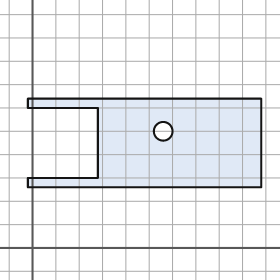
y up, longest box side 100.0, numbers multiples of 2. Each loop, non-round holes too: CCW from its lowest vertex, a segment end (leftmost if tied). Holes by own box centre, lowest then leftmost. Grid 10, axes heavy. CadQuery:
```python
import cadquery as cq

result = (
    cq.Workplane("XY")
    .moveTo(-2.0, 26.0)
    .lineTo(98.0, 26.0)
    .lineTo(98.0, 64.0)
    .lineTo(-2.0, 64.0)
    .lineTo(-2.0, 60.0)
    .lineTo(28.0, 60.0)
    .lineTo(28.0, 30.0)
    .lineTo(-2.0, 30.0)
    .close()
    .moveTo(56.0, 50.0)
    .circle(4.0)
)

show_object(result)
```